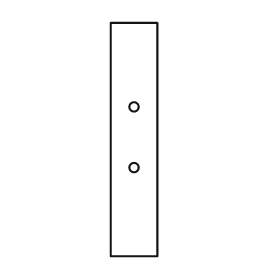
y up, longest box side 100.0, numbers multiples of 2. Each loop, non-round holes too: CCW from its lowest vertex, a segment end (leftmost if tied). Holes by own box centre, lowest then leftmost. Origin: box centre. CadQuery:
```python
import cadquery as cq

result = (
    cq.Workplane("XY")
    .moveTo(-10.0, -50.0)
    .lineTo(10.0, -50.0)
    .lineTo(10.0, 50.0)
    .lineTo(-10.0, 50.0)
    .close()
    .moveTo(0.0, -12.0)
    .circle(2.0)
    .moveTo(0.0, 14.0)
    .circle(2.0)
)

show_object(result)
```